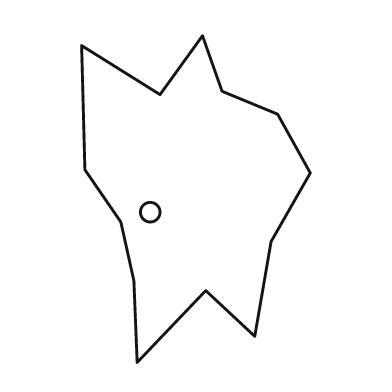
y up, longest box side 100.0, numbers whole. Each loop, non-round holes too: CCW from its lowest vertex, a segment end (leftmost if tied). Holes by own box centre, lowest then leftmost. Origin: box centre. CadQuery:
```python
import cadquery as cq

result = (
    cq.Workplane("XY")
    .moveTo(-18.0, -50.0)
    .lineTo(3.0, -28.0)
    .lineTo(18.0, -42.0)
    .lineTo(23.0, -13.0)
    .lineTo(35.0, 8.0)
    .lineTo(25.0, 26.0)
    .lineTo(8.0, 33.0)
    .lineTo(2.0, 50.0)
    .lineTo(-11.0, 32.0)
    .lineTo(-35.0, 47.0)
    .lineTo(-34.0, 9.0)
    .lineTo(-23.0, -7.0)
    .lineTo(-19.0, -25.0)
    .close()
    .moveTo(-14.0, -4.0)
    .circle(3.0)
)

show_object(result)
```